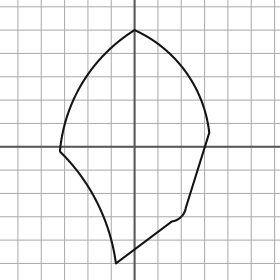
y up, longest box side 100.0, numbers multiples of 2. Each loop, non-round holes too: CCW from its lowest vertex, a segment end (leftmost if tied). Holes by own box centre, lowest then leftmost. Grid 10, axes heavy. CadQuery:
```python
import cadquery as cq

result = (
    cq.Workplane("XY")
    .moveTo(-8.0, -50.0)
    .lineTo(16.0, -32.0)
    .threePointArc((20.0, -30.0), (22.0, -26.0))
    .lineTo(32.0, 6.0)
    .threePointArc((22.0, 32.0), (0.0, 50.0))
    .threePointArc((-22.0, 28.0), (-32.0, -2.0))
    .threePointArc((-16.0, -24.0), (-8.0, -50.0))
    .close()
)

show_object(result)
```